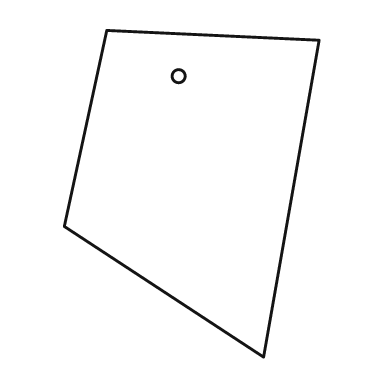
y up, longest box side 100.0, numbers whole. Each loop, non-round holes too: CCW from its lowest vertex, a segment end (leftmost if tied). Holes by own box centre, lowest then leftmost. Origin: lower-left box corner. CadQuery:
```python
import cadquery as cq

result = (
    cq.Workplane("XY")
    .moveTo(61.0, 0.0)
    .lineTo(78.0, 97.0)
    .lineTo(13.0, 100.0)
    .lineTo(0.0, 40.0)
    .close()
    .moveTo(35.0, 86.0)
    .circle(2.0)
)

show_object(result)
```